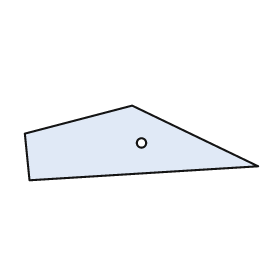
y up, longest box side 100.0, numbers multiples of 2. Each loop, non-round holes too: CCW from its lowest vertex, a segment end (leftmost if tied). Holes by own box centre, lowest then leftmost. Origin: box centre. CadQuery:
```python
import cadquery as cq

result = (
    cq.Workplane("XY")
    .moveTo(-48.0, -16.0)
    .lineTo(50.0, -10.0)
    .lineTo(-4.0, 16.0)
    .lineTo(-50.0, 4.0)
    .close()
    .moveTo(0.0, 0.0)
    .circle(2.0)
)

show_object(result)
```